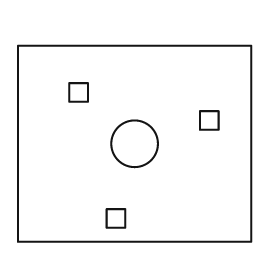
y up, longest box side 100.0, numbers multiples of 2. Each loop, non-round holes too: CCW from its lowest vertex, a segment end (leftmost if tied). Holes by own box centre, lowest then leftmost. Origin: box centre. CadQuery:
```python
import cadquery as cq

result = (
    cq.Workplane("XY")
    .moveTo(-50.0, -42.0)
    .lineTo(50.0, -42.0)
    .lineTo(50.0, 42.0)
    .lineTo(-50.0, 42.0)
    .close()
    .moveTo(-12.0, -36.0)
    .lineTo(-4.0, -36.0)
    .lineTo(-4.0, -28.0)
    .lineTo(-12.0, -28.0)
    .close()
    .moveTo(0.0, 0.0)
    .circle(10.0)
    .moveTo(28.0, 6.0)
    .lineTo(36.0, 6.0)
    .lineTo(36.0, 14.0)
    .lineTo(28.0, 14.0)
    .close()
    .moveTo(-28.0, 18.0)
    .lineTo(-20.0, 18.0)
    .lineTo(-20.0, 26.0)
    .lineTo(-28.0, 26.0)
    .close()
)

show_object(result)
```